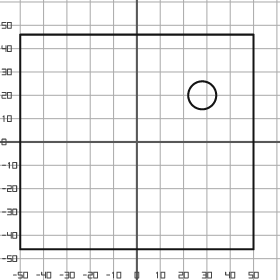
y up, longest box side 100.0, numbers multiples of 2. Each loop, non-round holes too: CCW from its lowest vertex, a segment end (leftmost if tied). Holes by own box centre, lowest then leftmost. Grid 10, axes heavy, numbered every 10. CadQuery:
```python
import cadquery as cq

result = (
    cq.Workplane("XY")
    .moveTo(-50.0, -46.0)
    .lineTo(50.0, -46.0)
    .lineTo(50.0, 46.0)
    .lineTo(-50.0, 46.0)
    .close()
    .moveTo(28.0, 20.0)
    .circle(6.0)
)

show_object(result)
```